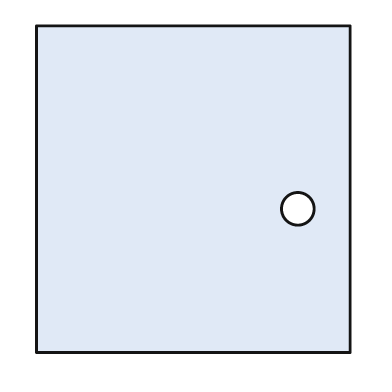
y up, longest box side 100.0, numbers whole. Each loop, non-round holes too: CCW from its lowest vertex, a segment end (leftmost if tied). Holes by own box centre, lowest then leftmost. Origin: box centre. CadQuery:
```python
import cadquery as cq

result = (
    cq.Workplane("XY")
    .moveTo(-48.0, -50.0)
    .lineTo(48.0, -50.0)
    .lineTo(48.0, 50.0)
    .lineTo(-48.0, 50.0)
    .close()
    .moveTo(32.0, -6.0)
    .circle(5.0)
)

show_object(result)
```